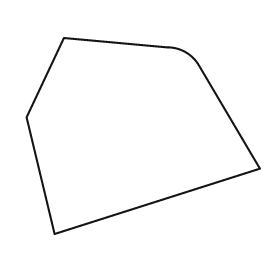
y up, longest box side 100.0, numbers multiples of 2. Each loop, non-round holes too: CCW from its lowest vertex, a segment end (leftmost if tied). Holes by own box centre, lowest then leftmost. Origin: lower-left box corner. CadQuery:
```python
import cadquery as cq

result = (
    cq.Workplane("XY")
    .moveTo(12.0, 0.0)
    .lineTo(100.0, 28.0)
    .lineTo(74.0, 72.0)
    .threePointArc((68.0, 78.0), (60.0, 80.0))
    .lineTo(16.0, 84.0)
    .lineTo(0.0, 50.0)
    .close()
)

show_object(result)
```